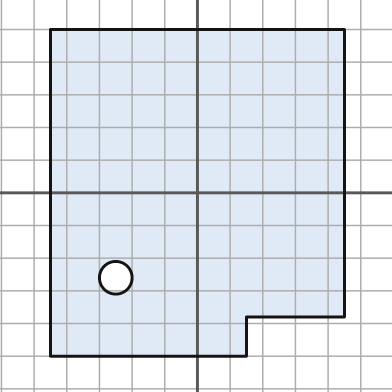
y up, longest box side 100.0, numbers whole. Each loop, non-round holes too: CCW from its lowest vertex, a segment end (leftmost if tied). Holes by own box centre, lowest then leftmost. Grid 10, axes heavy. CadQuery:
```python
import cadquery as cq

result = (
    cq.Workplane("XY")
    .moveTo(-45.0, -50.0)
    .lineTo(15.0, -50.0)
    .lineTo(15.0, -38.0)
    .lineTo(45.0, -38.0)
    .lineTo(45.0, 50.0)
    .lineTo(-45.0, 50.0)
    .close()
    .moveTo(-25.0, -26.0)
    .circle(5.0)
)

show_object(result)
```